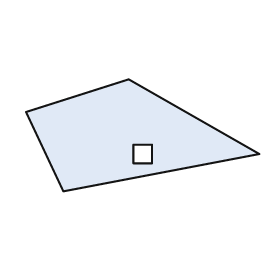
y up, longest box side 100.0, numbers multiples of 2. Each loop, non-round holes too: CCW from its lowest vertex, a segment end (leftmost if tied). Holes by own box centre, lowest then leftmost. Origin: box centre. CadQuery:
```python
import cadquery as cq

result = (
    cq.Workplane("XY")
    .moveTo(-34.0, -24.0)
    .lineTo(50.0, -8.0)
    .lineTo(-6.0, 24.0)
    .lineTo(-50.0, 10.0)
    .close()
    .moveTo(-4.0, -12.0)
    .lineTo(4.0, -12.0)
    .lineTo(4.0, -4.0)
    .lineTo(-4.0, -4.0)
    .close()
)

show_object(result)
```